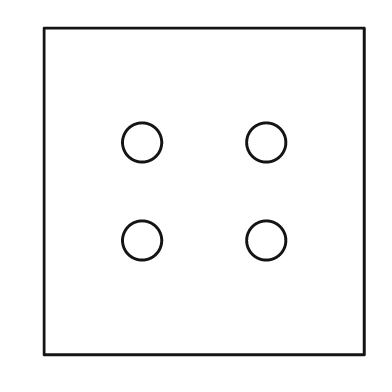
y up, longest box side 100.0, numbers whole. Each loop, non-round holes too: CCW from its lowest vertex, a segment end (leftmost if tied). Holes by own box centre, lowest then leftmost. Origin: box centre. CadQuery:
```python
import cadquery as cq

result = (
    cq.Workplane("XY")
    .moveTo(-49.0, -50.0)
    .lineTo(49.0, -50.0)
    .lineTo(49.0, 50.0)
    .lineTo(-49.0, 50.0)
    .close()
    .moveTo(-19.0, -15.0)
    .circle(6.0)
    .moveTo(19.0, -15.0)
    .circle(6.0)
    .moveTo(-19.0, 15.0)
    .circle(6.0)
    .moveTo(19.0, 15.0)
    .circle(6.0)
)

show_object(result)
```